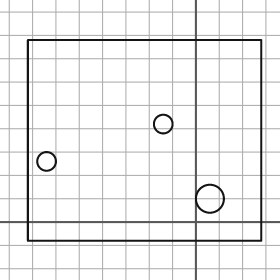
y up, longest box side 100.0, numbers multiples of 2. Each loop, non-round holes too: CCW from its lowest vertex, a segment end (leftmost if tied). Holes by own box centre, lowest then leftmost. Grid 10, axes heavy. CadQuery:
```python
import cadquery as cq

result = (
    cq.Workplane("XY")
    .moveTo(-72.0, -8.0)
    .lineTo(28.0, -8.0)
    .lineTo(28.0, 78.0)
    .lineTo(-72.0, 78.0)
    .close()
    .moveTo(6.0, 10.0)
    .circle(6.0)
    .moveTo(-64.0, 26.0)
    .circle(4.0)
    .moveTo(-14.0, 42.0)
    .circle(4.0)
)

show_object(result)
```